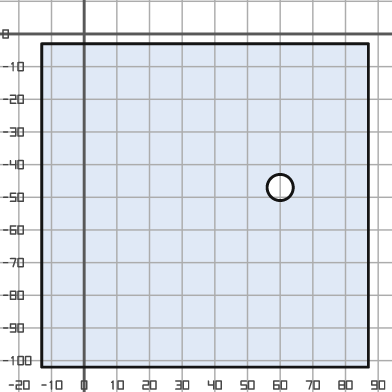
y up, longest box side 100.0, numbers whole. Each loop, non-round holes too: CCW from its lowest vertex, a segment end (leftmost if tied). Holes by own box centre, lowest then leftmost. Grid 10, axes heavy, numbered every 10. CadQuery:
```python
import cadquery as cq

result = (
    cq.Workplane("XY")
    .moveTo(-13.0, -102.0)
    .lineTo(87.0, -102.0)
    .lineTo(87.0, -3.0)
    .lineTo(-13.0, -3.0)
    .close()
    .moveTo(60.0, -47.0)
    .circle(4.0)
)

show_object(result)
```